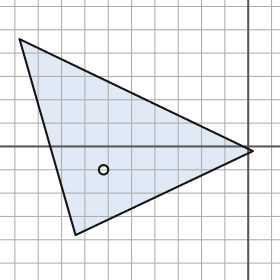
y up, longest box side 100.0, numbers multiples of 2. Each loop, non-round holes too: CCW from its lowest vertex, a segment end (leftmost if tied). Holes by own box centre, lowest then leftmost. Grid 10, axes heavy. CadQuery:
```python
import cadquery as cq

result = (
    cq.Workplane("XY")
    .moveTo(-74.0, -38.0)
    .lineTo(2.0, -2.0)
    .lineTo(-98.0, 46.0)
    .close()
    .moveTo(-62.0, -10.0)
    .circle(2.0)
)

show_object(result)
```